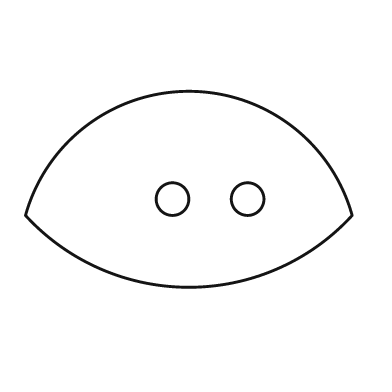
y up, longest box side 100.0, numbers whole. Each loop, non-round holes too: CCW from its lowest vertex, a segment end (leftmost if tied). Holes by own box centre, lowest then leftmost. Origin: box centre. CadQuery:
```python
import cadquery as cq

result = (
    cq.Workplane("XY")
    .moveTo(-50.0, -8.0)
    .threePointArc((0.0, -30.0), (50.0, -8.0))
    .threePointArc((0.0, 30.0), (-50.0, -8.0))
    .close()
    .moveTo(-5.0, -3.0)
    .circle(5.0)
    .moveTo(18.0, -3.0)
    .circle(5.0)
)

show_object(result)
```